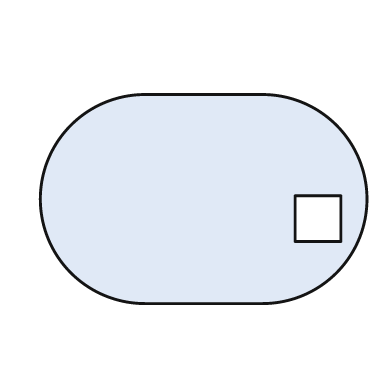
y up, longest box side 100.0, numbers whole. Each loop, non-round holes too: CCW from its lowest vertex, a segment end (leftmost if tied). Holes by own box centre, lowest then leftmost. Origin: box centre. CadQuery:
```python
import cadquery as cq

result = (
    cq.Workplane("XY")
    .moveTo(-18.0, -32.0)
    .lineTo(18.0, -32.0)
    .threePointArc((50.0, 0.0), (18.0, 32.0))
    .lineTo(-18.0, 32.0)
    .threePointArc((-50.0, 0.0), (-18.0, -32.0))
    .close()
    .moveTo(28.0, -13.0)
    .lineTo(42.0, -13.0)
    .lineTo(42.0, 1.0)
    .lineTo(28.0, 1.0)
    .close()
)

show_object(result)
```